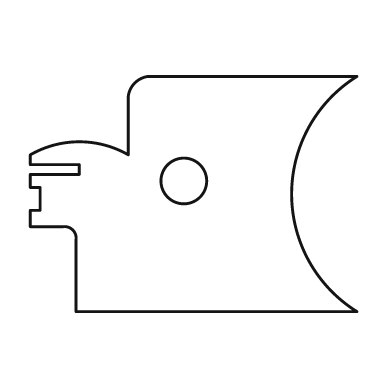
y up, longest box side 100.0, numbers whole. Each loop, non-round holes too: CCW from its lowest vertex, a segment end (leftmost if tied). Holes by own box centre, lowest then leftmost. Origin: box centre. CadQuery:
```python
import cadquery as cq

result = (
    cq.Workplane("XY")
    .moveTo(-36.0, -36.0)
    .lineTo(50.0, -36.0)
    .threePointArc((30.0, 0.0), (50.0, 36.0))
    .lineTo(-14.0, 36.0)
    .threePointArc((-18.0, 34.0), (-20.0, 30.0))
    .lineTo(-20.0, 12.0)
    .threePointArc((-35.0, 16.0), (-50.0, 12.0))
    .lineTo(-50.0, 9.0)
    .lineTo(-35.0, 9.0)
    .lineTo(-35.0, 6.0)
    .lineTo(-50.0, 6.0)
    .lineTo(-50.0, 2.0)
    .lineTo(-47.0, 2.0)
    .lineTo(-47.0, -5.0)
    .lineTo(-50.0, -5.0)
    .lineTo(-50.0, -10.0)
    .lineTo(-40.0, -10.0)
    .threePointArc((-37.0, -11.0), (-36.0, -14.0))
    .close()
    .moveTo(-3.0, 4.0)
    .circle(7.0)
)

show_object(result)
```